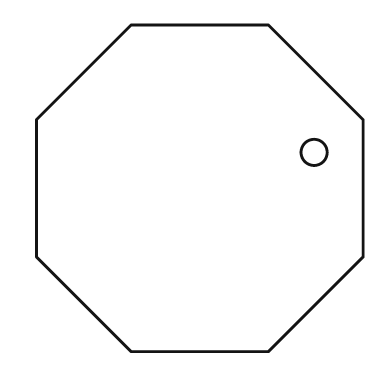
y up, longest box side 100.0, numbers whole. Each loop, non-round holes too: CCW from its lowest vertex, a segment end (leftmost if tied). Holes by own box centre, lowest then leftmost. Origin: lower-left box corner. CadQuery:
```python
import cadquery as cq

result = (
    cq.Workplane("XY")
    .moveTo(29.0, 0.0)
    .lineTo(71.0, 0.0)
    .lineTo(100.0, 29.0)
    .lineTo(100.0, 71.0)
    .lineTo(71.0, 100.0)
    .lineTo(29.0, 100.0)
    .lineTo(0.0, 71.0)
    .lineTo(0.0, 29.0)
    .close()
    .moveTo(85.0, 61.0)
    .circle(4.0)
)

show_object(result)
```